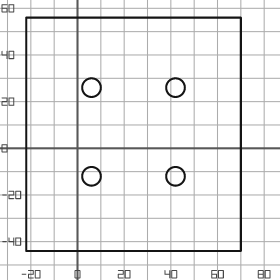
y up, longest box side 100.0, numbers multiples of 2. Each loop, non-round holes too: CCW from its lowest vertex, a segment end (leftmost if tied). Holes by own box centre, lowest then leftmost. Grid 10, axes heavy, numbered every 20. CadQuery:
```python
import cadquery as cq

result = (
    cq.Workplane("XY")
    .moveTo(-22.0, -44.0)
    .lineTo(70.0, -44.0)
    .lineTo(70.0, 56.0)
    .lineTo(-22.0, 56.0)
    .close()
    .moveTo(6.0, -12.0)
    .circle(4.0)
    .moveTo(42.0, -12.0)
    .circle(4.0)
    .moveTo(6.0, 26.0)
    .circle(4.0)
    .moveTo(42.0, 26.0)
    .circle(4.0)
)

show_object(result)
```